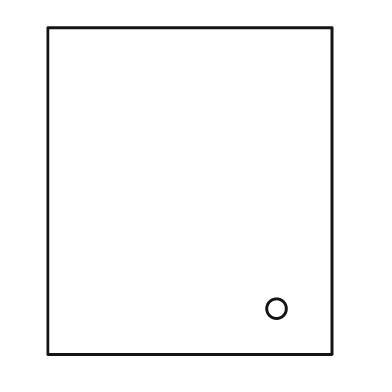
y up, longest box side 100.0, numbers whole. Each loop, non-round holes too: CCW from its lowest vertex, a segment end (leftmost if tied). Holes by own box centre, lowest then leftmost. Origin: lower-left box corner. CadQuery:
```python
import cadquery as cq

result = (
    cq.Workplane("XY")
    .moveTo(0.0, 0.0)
    .lineTo(87.0, 0.0)
    .lineTo(87.0, 100.0)
    .lineTo(0.0, 100.0)
    .close()
    .moveTo(70.0, 14.0)
    .circle(3.0)
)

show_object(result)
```